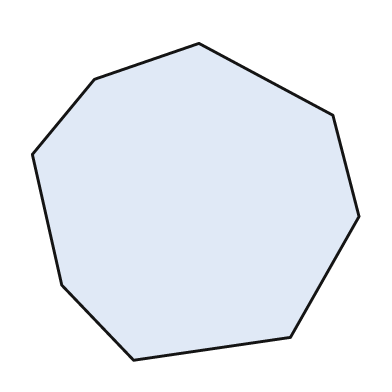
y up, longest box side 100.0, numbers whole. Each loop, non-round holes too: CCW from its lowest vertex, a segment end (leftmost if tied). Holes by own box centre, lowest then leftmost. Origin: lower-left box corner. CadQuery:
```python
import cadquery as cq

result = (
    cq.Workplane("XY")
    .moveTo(31.0, 0.0)
    .lineTo(79.0, 7.0)
    .lineTo(100.0, 44.0)
    .lineTo(92.0, 75.0)
    .lineTo(51.0, 97.0)
    .lineTo(19.0, 86.0)
    .lineTo(0.0, 63.0)
    .lineTo(9.0, 23.0)
    .close()
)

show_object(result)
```